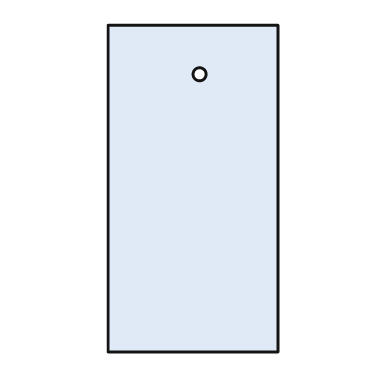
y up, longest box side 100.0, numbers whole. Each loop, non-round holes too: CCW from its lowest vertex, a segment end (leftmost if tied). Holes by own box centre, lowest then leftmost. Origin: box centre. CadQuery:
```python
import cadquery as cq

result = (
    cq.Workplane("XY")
    .moveTo(-26.0, -50.0)
    .lineTo(26.0, -50.0)
    .lineTo(26.0, 50.0)
    .lineTo(-26.0, 50.0)
    .close()
    .moveTo(2.0, 35.0)
    .circle(2.0)
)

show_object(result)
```